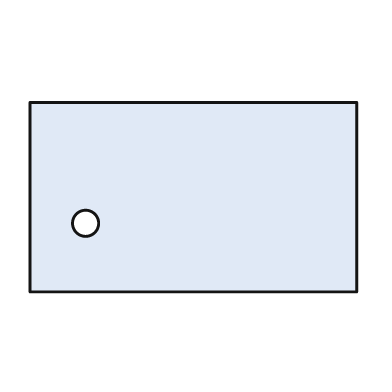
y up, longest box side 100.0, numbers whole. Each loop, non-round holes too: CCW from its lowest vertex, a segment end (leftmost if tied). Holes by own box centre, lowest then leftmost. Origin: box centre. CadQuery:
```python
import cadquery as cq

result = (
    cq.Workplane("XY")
    .moveTo(-50.0, -29.0)
    .lineTo(50.0, -29.0)
    .lineTo(50.0, 29.0)
    .lineTo(-50.0, 29.0)
    .close()
    .moveTo(-33.0, -8.0)
    .circle(4.0)
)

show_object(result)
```